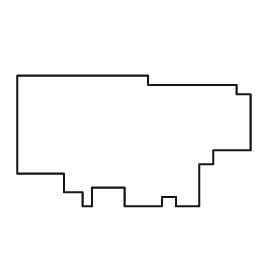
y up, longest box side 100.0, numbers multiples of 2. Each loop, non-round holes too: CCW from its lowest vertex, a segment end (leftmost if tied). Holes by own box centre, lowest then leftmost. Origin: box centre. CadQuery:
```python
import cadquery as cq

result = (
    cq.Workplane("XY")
    .moveTo(-22.0, -28.0)
    .lineTo(-18.0, -28.0)
    .lineTo(-18.0, -20.0)
    .lineTo(-4.0, -20.0)
    .lineTo(-4.0, -28.0)
    .lineTo(12.0, -28.0)
    .lineTo(12.0, -24.0)
    .lineTo(18.0, -24.0)
    .lineTo(18.0, -28.0)
    .lineTo(28.0, -28.0)
    .lineTo(28.0, -10.0)
    .lineTo(34.0, -10.0)
    .lineTo(34.0, -4.0)
    .lineTo(50.0, -4.0)
    .lineTo(50.0, 20.0)
    .lineTo(44.0, 20.0)
    .lineTo(44.0, 24.0)
    .lineTo(6.0, 24.0)
    .lineTo(6.0, 28.0)
    .lineTo(-50.0, 28.0)
    .lineTo(-50.0, -14.0)
    .lineTo(-30.0, -14.0)
    .lineTo(-30.0, -22.0)
    .lineTo(-22.0, -22.0)
    .close()
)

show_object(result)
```